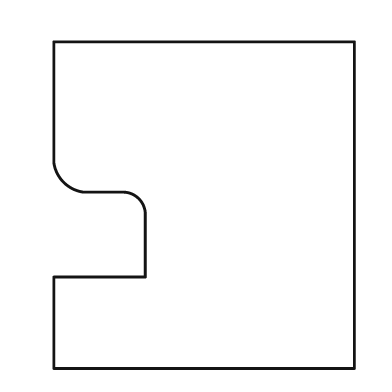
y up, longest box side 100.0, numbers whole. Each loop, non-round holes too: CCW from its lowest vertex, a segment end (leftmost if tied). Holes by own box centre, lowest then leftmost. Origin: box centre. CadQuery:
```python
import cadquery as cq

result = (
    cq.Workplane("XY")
    .moveTo(-46.0, -50.0)
    .lineTo(46.0, -50.0)
    .lineTo(46.0, 50.0)
    .lineTo(-46.0, 50.0)
    .lineTo(-46.0, 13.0)
    .threePointArc((-43.0, 7.0), (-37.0, 4.0))
    .lineTo(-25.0, 4.0)
    .threePointArc((-20.0, 2.0), (-18.0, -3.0))
    .lineTo(-18.0, -22.0)
    .lineTo(-46.0, -22.0)
    .close()
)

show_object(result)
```